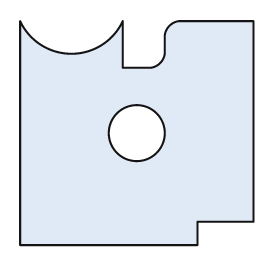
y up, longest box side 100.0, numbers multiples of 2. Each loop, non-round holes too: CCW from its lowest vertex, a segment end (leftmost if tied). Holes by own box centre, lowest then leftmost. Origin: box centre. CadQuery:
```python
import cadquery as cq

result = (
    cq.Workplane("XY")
    .moveTo(-50.0, -48.0)
    .lineTo(26.0, -48.0)
    .lineTo(26.0, -38.0)
    .lineTo(50.0, -38.0)
    .lineTo(50.0, 48.0)
    .lineTo(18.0, 48.0)
    .threePointArc((14.0, 46.0), (12.0, 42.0))
    .lineTo(12.0, 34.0)
    .threePointArc((10.0, 30.0), (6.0, 28.0))
    .lineTo(-6.0, 28.0)
    .lineTo(-6.0, 48.0)
    .threePointArc((-28.0, 34.0), (-50.0, 48.0))
    .close()
    .moveTo(0.0, 0.0)
    .circle(12.0)
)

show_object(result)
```